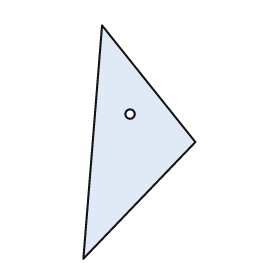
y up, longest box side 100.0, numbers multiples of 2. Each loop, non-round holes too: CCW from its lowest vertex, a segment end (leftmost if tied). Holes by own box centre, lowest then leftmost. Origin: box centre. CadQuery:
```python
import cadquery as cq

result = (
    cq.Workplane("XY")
    .moveTo(-24.0, -50.0)
    .lineTo(24.0, 0.0)
    .lineTo(-16.0, 50.0)
    .close()
    .moveTo(-4.0, 12.0)
    .circle(2.0)
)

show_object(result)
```